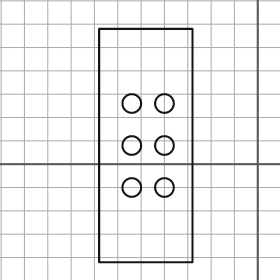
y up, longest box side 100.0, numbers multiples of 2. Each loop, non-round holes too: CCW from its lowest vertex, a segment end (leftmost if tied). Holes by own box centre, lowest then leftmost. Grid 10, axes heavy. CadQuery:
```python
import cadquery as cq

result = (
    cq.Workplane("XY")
    .moveTo(-68.0, -42.0)
    .lineTo(-28.0, -42.0)
    .lineTo(-28.0, 58.0)
    .lineTo(-68.0, 58.0)
    .close()
    .moveTo(-54.0, -10.0)
    .circle(4.0)
    .moveTo(-40.0, -10.0)
    .circle(4.0)
    .moveTo(-54.0, 8.0)
    .circle(4.0)
    .moveTo(-40.0, 8.0)
    .circle(4.0)
    .moveTo(-54.0, 26.0)
    .circle(4.0)
    .moveTo(-40.0, 26.0)
    .circle(4.0)
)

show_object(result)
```